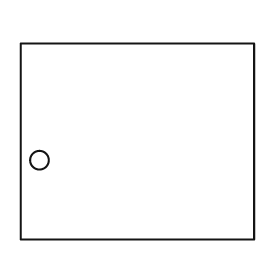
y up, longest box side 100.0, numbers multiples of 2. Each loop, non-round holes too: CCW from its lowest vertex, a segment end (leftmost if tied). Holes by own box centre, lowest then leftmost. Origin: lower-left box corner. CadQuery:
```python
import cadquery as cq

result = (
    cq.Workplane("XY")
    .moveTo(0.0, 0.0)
    .lineTo(100.0, 0.0)
    .lineTo(100.0, 84.0)
    .lineTo(0.0, 84.0)
    .close()
    .moveTo(8.0, 34.0)
    .circle(4.0)
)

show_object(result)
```